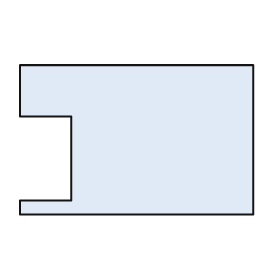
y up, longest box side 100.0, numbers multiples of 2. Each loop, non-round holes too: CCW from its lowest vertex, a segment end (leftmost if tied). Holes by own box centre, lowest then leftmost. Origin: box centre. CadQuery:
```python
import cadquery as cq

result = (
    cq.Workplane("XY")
    .moveTo(-50.0, -32.0)
    .lineTo(50.0, -32.0)
    .lineTo(50.0, 32.0)
    .lineTo(-50.0, 32.0)
    .lineTo(-50.0, 10.0)
    .lineTo(-28.0, 10.0)
    .lineTo(-28.0, -26.0)
    .lineTo(-50.0, -26.0)
    .close()
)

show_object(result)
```